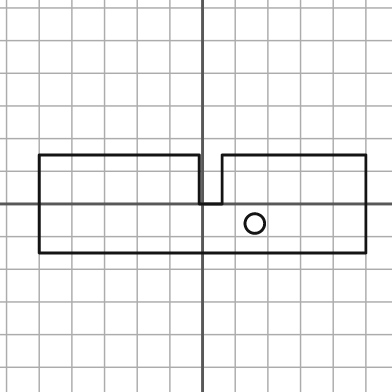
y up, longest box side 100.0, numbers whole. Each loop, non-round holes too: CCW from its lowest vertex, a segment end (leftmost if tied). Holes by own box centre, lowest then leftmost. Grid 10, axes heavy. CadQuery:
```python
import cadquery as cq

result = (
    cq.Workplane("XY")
    .moveTo(-50.0, -15.0)
    .lineTo(50.0, -15.0)
    .lineTo(50.0, 15.0)
    .lineTo(6.0, 15.0)
    .lineTo(6.0, 0.0)
    .lineTo(-1.0, 0.0)
    .lineTo(-1.0, 15.0)
    .lineTo(-50.0, 15.0)
    .close()
    .moveTo(16.0, -6.0)
    .circle(3.0)
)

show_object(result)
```